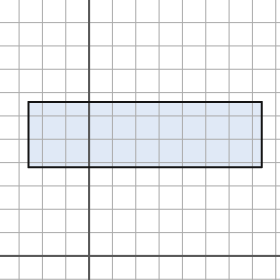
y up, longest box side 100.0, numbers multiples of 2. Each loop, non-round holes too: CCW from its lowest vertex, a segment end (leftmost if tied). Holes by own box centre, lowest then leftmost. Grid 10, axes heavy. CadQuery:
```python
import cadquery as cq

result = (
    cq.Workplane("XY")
    .moveTo(-26.0, 38.0)
    .lineTo(74.0, 38.0)
    .lineTo(74.0, 66.0)
    .lineTo(-26.0, 66.0)
    .close()
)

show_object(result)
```